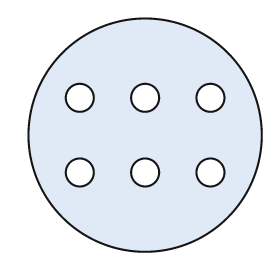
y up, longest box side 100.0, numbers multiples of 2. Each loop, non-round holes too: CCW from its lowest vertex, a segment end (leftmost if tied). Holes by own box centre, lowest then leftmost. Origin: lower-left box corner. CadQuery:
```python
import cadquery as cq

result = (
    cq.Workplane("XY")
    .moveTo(50.0, 50.0)
    .circle(50.0)
    .moveTo(22.0, 34.0)
    .circle(6.0)
    .moveTo(50.0, 34.0)
    .circle(6.0)
    .moveTo(78.0, 34.0)
    .circle(6.0)
    .moveTo(22.0, 66.0)
    .circle(6.0)
    .moveTo(50.0, 66.0)
    .circle(6.0)
    .moveTo(78.0, 66.0)
    .circle(6.0)
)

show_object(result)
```